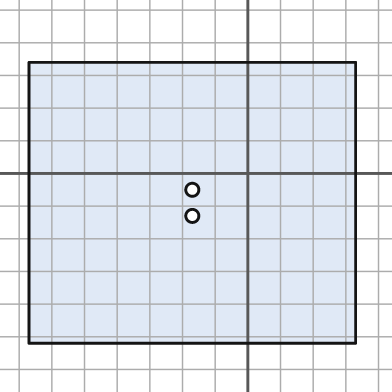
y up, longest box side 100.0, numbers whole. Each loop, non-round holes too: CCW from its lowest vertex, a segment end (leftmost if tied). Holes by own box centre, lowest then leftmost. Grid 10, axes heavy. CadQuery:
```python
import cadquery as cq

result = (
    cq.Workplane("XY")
    .moveTo(-67.0, -52.0)
    .lineTo(33.0, -52.0)
    .lineTo(33.0, 34.0)
    .lineTo(-67.0, 34.0)
    .close()
    .moveTo(-17.0, -13.0)
    .circle(2.0)
    .moveTo(-17.0, -5.0)
    .circle(2.0)
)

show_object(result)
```